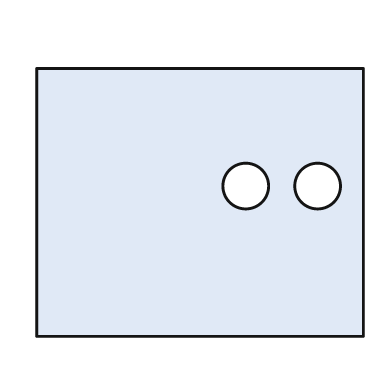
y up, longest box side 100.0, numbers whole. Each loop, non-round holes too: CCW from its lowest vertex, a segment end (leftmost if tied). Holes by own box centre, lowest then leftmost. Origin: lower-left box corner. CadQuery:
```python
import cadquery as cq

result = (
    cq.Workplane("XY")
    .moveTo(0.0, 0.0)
    .lineTo(100.0, 0.0)
    .lineTo(100.0, 82.0)
    .lineTo(0.0, 82.0)
    .close()
    .moveTo(64.0, 46.0)
    .circle(7.0)
    .moveTo(86.0, 46.0)
    .circle(7.0)
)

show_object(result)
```